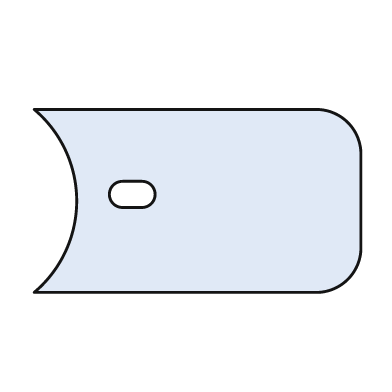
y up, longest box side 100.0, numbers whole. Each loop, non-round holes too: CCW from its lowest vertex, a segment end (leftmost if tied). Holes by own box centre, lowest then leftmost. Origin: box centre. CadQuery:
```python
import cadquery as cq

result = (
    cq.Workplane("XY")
    .moveTo(-50.0, -28.0)
    .lineTo(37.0, -28.0)
    .threePointArc((46.0, -24.0), (50.0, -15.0))
    .lineTo(50.0, 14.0)
    .threePointArc((46.0, 24.0), (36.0, 28.0))
    .lineTo(-50.0, 28.0)
    .threePointArc((-37.0, 0.0), (-50.0, -28.0))
    .close()
    .moveTo(-23.0, -2.0)
    .lineTo(-17.0, -2.0)
    .threePointArc((-13.0, 2.0), (-17.0, 6.0))
    .lineTo(-23.0, 6.0)
    .threePointArc((-27.0, 2.0), (-23.0, -2.0))
    .close()
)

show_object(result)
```